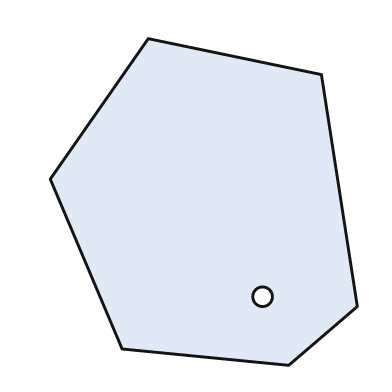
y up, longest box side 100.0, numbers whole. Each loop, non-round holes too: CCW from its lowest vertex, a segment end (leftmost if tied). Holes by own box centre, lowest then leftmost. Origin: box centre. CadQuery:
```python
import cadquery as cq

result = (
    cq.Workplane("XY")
    .moveTo(26.0, -50.0)
    .lineTo(47.0, -32.0)
    .lineTo(36.0, 39.0)
    .lineTo(-17.0, 50.0)
    .lineTo(-47.0, 7.0)
    .lineTo(-25.0, -45.0)
    .close()
    .moveTo(18.0, -29.0)
    .circle(3.0)
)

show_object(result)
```